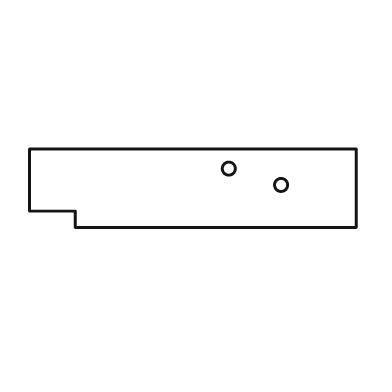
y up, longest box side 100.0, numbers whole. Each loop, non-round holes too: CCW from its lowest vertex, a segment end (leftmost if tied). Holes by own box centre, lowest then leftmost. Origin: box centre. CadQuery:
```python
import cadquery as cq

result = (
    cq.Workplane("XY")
    .moveTo(-36.0, -12.0)
    .lineTo(50.0, -12.0)
    .lineTo(50.0, 12.0)
    .lineTo(-50.0, 12.0)
    .lineTo(-50.0, -7.0)
    .lineTo(-36.0, -7.0)
    .close()
    .moveTo(27.0, 1.0)
    .circle(2.0)
    .moveTo(11.0, 6.0)
    .circle(2.0)
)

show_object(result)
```